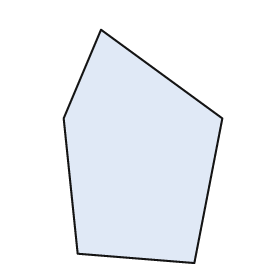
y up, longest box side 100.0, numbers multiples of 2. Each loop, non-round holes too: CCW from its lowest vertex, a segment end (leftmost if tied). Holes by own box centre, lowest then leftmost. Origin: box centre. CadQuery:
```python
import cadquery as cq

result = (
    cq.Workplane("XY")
    .moveTo(22.0, -50.0)
    .lineTo(34.0, 12.0)
    .lineTo(-18.0, 50.0)
    .lineTo(-34.0, 12.0)
    .lineTo(-28.0, -46.0)
    .close()
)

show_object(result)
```